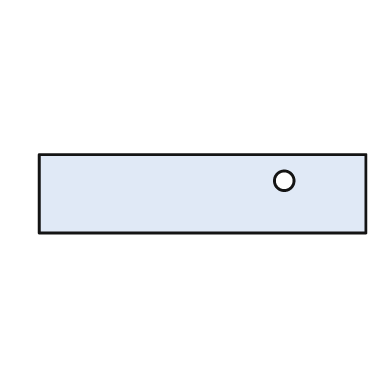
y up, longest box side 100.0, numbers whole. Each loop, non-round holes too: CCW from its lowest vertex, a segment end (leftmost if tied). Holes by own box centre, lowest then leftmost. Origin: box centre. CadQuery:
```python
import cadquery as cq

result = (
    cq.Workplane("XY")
    .moveTo(-50.0, -12.0)
    .lineTo(50.0, -12.0)
    .lineTo(50.0, 12.0)
    .lineTo(-50.0, 12.0)
    .close()
    .moveTo(25.0, 4.0)
    .circle(3.0)
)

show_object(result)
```